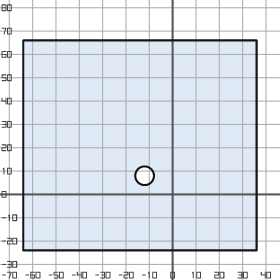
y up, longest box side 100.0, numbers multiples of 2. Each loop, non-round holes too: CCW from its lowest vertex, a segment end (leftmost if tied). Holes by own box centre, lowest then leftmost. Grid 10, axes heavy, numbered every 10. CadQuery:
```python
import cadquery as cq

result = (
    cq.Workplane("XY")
    .moveTo(-64.0, -24.0)
    .lineTo(36.0, -24.0)
    .lineTo(36.0, 66.0)
    .lineTo(-64.0, 66.0)
    .close()
    .moveTo(-12.0, 8.0)
    .circle(4.0)
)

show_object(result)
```